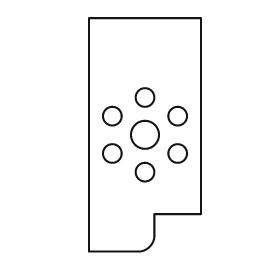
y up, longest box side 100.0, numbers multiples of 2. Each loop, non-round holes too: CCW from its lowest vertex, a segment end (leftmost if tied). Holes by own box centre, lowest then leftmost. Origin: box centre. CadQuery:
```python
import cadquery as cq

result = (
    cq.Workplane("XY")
    .moveTo(-24.0, -50.0)
    .lineTo(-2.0, -50.0)
    .threePointArc((2.0, -48.0), (4.0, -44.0))
    .lineTo(4.0, -34.0)
    .lineTo(24.0, -34.0)
    .lineTo(24.0, 50.0)
    .lineTo(-24.0, 50.0)
    .close()
    .moveTo(0.0, -16.0)
    .circle(4.0)
    .moveTo(-14.0, -8.0)
    .circle(4.0)
    .moveTo(14.0, -8.0)
    .circle(4.0)
    .moveTo(0.0, 0.0)
    .circle(6.0)
    .moveTo(-14.0, 8.0)
    .circle(4.0)
    .moveTo(14.0, 8.0)
    .circle(4.0)
    .moveTo(0.0, 16.0)
    .circle(4.0)
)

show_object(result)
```